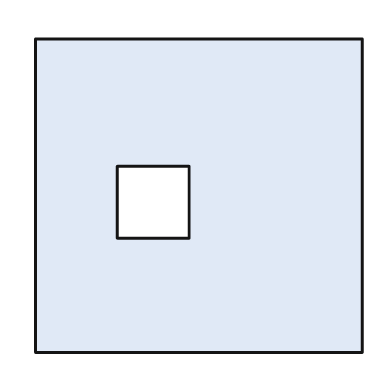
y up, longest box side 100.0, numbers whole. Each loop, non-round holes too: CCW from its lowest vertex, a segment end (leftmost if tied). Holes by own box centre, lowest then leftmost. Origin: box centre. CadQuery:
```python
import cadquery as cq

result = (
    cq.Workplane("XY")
    .moveTo(-50.0, -48.0)
    .lineTo(50.0, -48.0)
    .lineTo(50.0, 48.0)
    .lineTo(-50.0, 48.0)
    .close()
    .moveTo(-25.0, -13.0)
    .lineTo(-3.0, -13.0)
    .lineTo(-3.0, 9.0)
    .lineTo(-25.0, 9.0)
    .close()
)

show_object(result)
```